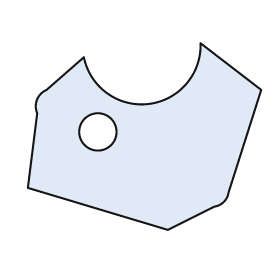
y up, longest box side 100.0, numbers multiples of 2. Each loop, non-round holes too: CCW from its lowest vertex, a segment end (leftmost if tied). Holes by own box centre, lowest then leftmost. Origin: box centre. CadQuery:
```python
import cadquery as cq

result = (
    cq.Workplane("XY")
    .moveTo(10.0, -40.0)
    .lineTo(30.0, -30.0)
    .threePointArc((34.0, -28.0), (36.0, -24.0))
    .lineTo(50.0, 20.0)
    .lineTo(24.0, 40.0)
    .threePointArc((2.0, 14.0), (-26.0, 34.0))
    .lineTo(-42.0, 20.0)
    .threePointArc((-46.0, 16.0), (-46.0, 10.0))
    .lineTo(-50.0, -22.0)
    .close()
    .moveTo(-20.0, 2.0)
    .circle(8.0)
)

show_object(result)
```